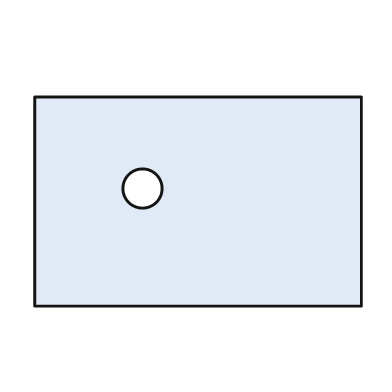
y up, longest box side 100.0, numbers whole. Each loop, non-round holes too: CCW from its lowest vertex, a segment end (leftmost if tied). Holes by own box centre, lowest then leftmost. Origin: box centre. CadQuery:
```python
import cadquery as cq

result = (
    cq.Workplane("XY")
    .moveTo(-50.0, -32.0)
    .lineTo(50.0, -32.0)
    .lineTo(50.0, 32.0)
    .lineTo(-50.0, 32.0)
    .close()
    .moveTo(-17.0, 4.0)
    .circle(6.0)
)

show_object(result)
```